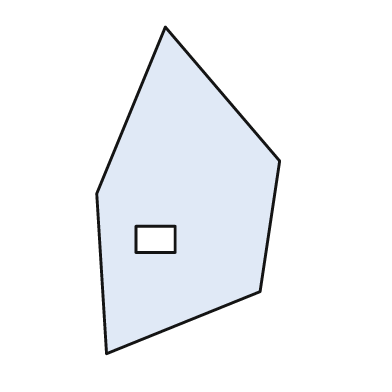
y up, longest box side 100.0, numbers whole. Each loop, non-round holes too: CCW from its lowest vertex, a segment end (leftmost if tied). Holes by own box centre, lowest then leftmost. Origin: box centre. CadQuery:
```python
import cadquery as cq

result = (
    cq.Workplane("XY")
    .moveTo(-25.0, -50.0)
    .lineTo(22.0, -31.0)
    .lineTo(28.0, 9.0)
    .lineTo(-7.0, 50.0)
    .lineTo(-28.0, -1.0)
    .close()
    .moveTo(-16.0, -19.0)
    .lineTo(-4.0, -19.0)
    .lineTo(-4.0, -11.0)
    .lineTo(-16.0, -11.0)
    .close()
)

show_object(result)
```